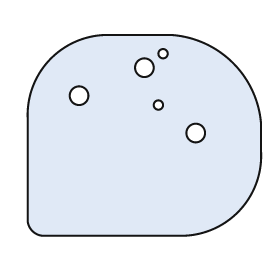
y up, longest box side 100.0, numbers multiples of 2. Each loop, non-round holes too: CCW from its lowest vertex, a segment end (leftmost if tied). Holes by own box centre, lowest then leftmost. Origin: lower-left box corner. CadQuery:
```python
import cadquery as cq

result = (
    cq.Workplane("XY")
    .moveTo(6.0, 0.0)
    .lineTo(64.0, 0.0)
    .threePointArc((90.0, 10.0), (100.0, 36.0))
    .lineTo(100.0, 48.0)
    .threePointArc((88.0, 74.0), (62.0, 86.0))
    .lineTo(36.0, 86.0)
    .threePointArc((10.0, 76.0), (0.0, 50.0))
    .lineTo(0.0, 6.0)
    .threePointArc((2.0, 2.0), (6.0, 0.0))
    .close()
    .moveTo(72.0, 44.0)
    .circle(4.0)
    .moveTo(56.0, 56.0)
    .circle(2.0)
    .moveTo(22.0, 60.0)
    .circle(4.0)
    .moveTo(50.0, 72.0)
    .circle(4.0)
    .moveTo(58.0, 78.0)
    .circle(2.0)
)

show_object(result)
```